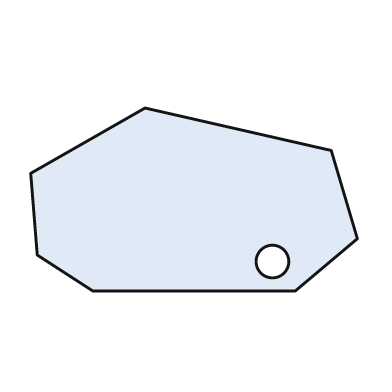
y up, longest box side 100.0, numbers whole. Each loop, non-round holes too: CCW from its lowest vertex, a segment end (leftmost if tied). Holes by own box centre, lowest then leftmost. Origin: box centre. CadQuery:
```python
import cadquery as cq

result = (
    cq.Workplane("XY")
    .moveTo(-31.0, -28.0)
    .lineTo(31.0, -28.0)
    .lineTo(50.0, -12.0)
    .lineTo(42.0, 15.0)
    .lineTo(-15.0, 28.0)
    .lineTo(-50.0, 8.0)
    .lineTo(-48.0, -17.0)
    .close()
    .moveTo(24.0, -19.0)
    .circle(5.0)
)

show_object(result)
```